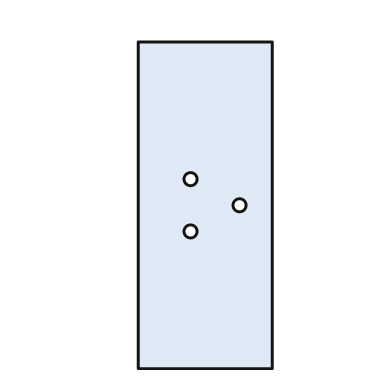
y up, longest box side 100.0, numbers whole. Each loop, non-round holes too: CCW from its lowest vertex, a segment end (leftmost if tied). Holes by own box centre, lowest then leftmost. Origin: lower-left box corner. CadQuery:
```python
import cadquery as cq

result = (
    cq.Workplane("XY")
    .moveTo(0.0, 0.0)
    .lineTo(41.0, 0.0)
    .lineTo(41.0, 100.0)
    .lineTo(0.0, 100.0)
    .close()
    .moveTo(16.0, 42.0)
    .circle(2.0)
    .moveTo(31.0, 50.0)
    .circle(2.0)
    .moveTo(16.0, 58.0)
    .circle(2.0)
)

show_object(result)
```